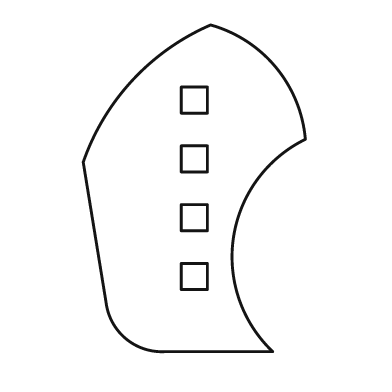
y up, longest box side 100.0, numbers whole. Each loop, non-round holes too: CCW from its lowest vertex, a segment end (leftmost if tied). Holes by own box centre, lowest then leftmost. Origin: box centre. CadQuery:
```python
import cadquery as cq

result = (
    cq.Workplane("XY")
    .moveTo(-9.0, -50.0)
    .lineTo(24.0, -50.0)
    .threePointArc((12.0, -15.0), (34.0, 15.0))
    .threePointArc((25.0, 37.0), (5.0, 50.0))
    .threePointArc((-19.0, 33.0), (-34.0, 8.0))
    .lineTo(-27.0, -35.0)
    .threePointArc((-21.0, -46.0), (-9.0, -50.0))
    .close()
    .moveTo(-4.0, -31.0)
    .lineTo(4.0, -31.0)
    .lineTo(4.0, -23.0)
    .lineTo(-4.0, -23.0)
    .close()
    .moveTo(-4.0, -13.0)
    .lineTo(4.0, -13.0)
    .lineTo(4.0, -5.0)
    .lineTo(-4.0, -5.0)
    .close()
    .moveTo(-4.0, 5.0)
    .lineTo(4.0, 5.0)
    .lineTo(4.0, 13.0)
    .lineTo(-4.0, 13.0)
    .close()
    .moveTo(-4.0, 23.0)
    .lineTo(4.0, 23.0)
    .lineTo(4.0, 31.0)
    .lineTo(-4.0, 31.0)
    .close()
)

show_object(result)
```